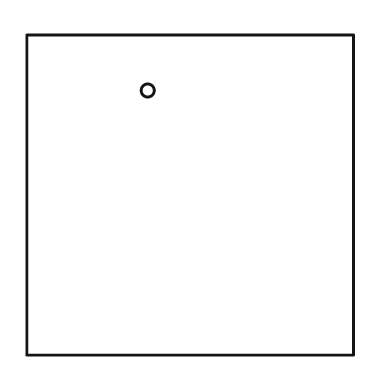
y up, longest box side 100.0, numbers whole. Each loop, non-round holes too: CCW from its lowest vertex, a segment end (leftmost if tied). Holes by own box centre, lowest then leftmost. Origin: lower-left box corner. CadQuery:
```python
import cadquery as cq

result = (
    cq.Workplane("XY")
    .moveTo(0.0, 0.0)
    .lineTo(100.0, 0.0)
    .lineTo(100.0, 98.0)
    .lineTo(0.0, 98.0)
    .close()
    .moveTo(37.0, 81.0)
    .circle(2.0)
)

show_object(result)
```